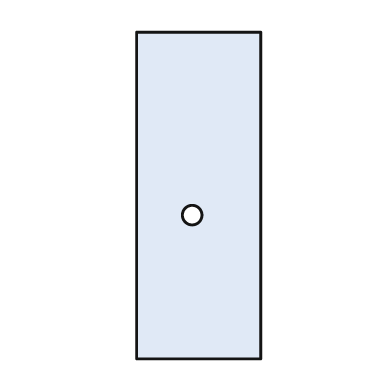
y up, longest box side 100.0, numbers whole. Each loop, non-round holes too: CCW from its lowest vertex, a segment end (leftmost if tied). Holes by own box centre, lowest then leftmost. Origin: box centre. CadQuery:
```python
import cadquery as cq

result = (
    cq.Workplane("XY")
    .moveTo(-19.0, -50.0)
    .lineTo(19.0, -50.0)
    .lineTo(19.0, 50.0)
    .lineTo(-19.0, 50.0)
    .close()
    .moveTo(-2.0, -6.0)
    .circle(3.0)
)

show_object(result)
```